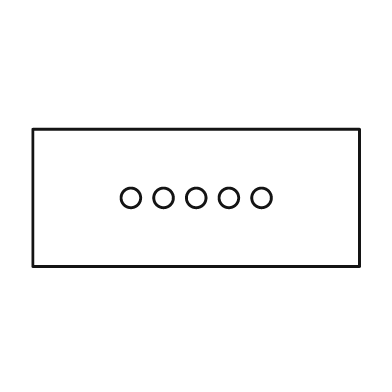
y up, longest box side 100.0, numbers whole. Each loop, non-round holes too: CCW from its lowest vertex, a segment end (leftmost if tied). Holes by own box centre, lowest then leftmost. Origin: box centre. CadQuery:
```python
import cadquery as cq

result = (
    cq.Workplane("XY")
    .moveTo(-50.0, -21.0)
    .lineTo(50.0, -21.0)
    .lineTo(50.0, 21.0)
    .lineTo(-50.0, 21.0)
    .close()
    .moveTo(-20.0, 0.0)
    .circle(3.0)
    .moveTo(-10.0, 0.0)
    .circle(3.0)
    .moveTo(0.0, 0.0)
    .circle(3.0)
    .moveTo(10.0, 0.0)
    .circle(3.0)
    .moveTo(20.0, 0.0)
    .circle(3.0)
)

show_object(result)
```